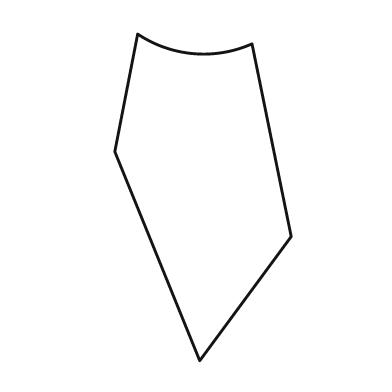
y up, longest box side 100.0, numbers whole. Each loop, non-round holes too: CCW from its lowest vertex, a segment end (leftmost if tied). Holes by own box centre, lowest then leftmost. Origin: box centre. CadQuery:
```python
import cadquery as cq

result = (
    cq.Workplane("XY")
    .moveTo(-1.0, -50.0)
    .lineTo(27.0, -12.0)
    .lineTo(15.0, 47.0)
    .threePointArc((-3.0, 44.0), (-20.0, 50.0))
    .lineTo(-27.0, 14.0)
    .close()
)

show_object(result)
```